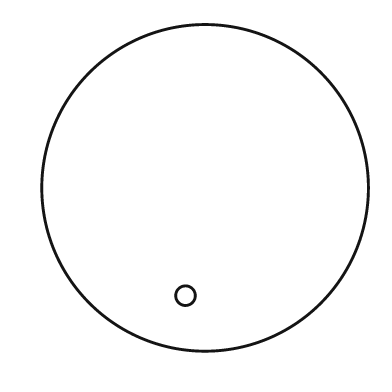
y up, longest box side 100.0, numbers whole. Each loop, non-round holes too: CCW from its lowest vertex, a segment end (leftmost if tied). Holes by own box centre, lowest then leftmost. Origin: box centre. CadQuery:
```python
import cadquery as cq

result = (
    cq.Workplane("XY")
    .moveTo(0.0, 0.0)
    .circle(50.0)
    .moveTo(-6.0, -33.0)
    .circle(3.0)
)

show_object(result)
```